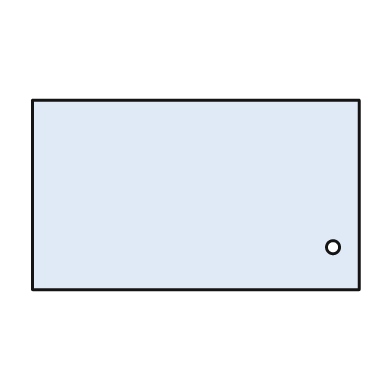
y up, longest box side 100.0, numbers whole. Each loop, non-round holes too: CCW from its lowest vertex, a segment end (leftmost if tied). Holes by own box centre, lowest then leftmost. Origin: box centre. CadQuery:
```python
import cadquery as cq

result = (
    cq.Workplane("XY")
    .moveTo(-50.0, -29.0)
    .lineTo(50.0, -29.0)
    .lineTo(50.0, 29.0)
    .lineTo(-50.0, 29.0)
    .close()
    .moveTo(42.0, -16.0)
    .circle(2.0)
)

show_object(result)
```